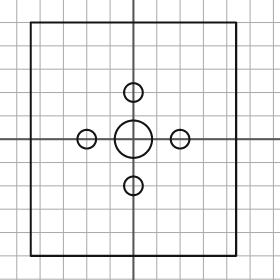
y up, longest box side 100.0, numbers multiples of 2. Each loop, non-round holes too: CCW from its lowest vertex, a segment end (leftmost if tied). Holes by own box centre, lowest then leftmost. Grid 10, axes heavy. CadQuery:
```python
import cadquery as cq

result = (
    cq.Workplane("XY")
    .moveTo(-44.0, -50.0)
    .lineTo(44.0, -50.0)
    .lineTo(44.0, 50.0)
    .lineTo(-44.0, 50.0)
    .close()
    .moveTo(0.0, -20.0)
    .circle(4.0)
    .moveTo(-20.0, 0.0)
    .circle(4.0)
    .moveTo(0.0, 0.0)
    .circle(8.0)
    .moveTo(20.0, 0.0)
    .circle(4.0)
    .moveTo(0.0, 20.0)
    .circle(4.0)
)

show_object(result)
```